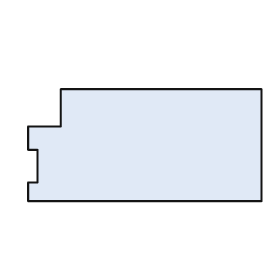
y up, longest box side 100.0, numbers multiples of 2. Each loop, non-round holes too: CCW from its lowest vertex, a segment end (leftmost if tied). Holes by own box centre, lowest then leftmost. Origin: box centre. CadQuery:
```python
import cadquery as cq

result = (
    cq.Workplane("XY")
    .moveTo(-50.0, -24.0)
    .lineTo(50.0, -24.0)
    .lineTo(50.0, 24.0)
    .lineTo(-36.0, 24.0)
    .lineTo(-36.0, 8.0)
    .lineTo(-50.0, 8.0)
    .lineTo(-50.0, -2.0)
    .lineTo(-46.0, -2.0)
    .lineTo(-46.0, -16.0)
    .lineTo(-50.0, -16.0)
    .close()
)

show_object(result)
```